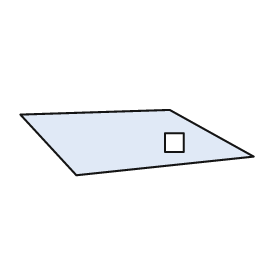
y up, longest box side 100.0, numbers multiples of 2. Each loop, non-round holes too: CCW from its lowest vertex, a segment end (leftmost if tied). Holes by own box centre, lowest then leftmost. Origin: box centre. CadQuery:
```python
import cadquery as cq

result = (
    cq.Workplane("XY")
    .moveTo(-26.0, -14.0)
    .lineTo(50.0, -6.0)
    .lineTo(14.0, 14.0)
    .lineTo(-50.0, 12.0)
    .close()
    .moveTo(12.0, -4.0)
    .lineTo(20.0, -4.0)
    .lineTo(20.0, 4.0)
    .lineTo(12.0, 4.0)
    .close()
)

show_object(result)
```